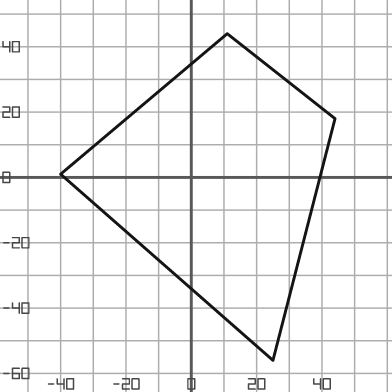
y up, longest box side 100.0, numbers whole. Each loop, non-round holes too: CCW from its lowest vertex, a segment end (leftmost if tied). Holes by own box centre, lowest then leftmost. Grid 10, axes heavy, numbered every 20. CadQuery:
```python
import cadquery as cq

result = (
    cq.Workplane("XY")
    .moveTo(25.0, -56.0)
    .lineTo(44.0, 18.0)
    .lineTo(11.0, 44.0)
    .lineTo(-40.0, 1.0)
    .close()
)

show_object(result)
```